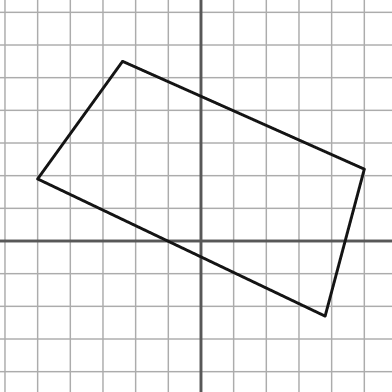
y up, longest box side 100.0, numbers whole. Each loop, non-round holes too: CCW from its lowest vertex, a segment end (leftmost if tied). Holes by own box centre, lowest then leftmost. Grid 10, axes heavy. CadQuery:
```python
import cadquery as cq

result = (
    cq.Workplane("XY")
    .moveTo(38.0, -23.0)
    .lineTo(50.0, 22.0)
    .lineTo(-24.0, 55.0)
    .lineTo(-50.0, 19.0)
    .close()
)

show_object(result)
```